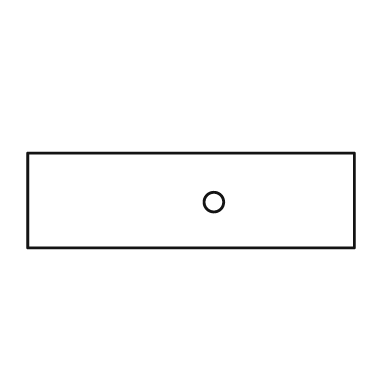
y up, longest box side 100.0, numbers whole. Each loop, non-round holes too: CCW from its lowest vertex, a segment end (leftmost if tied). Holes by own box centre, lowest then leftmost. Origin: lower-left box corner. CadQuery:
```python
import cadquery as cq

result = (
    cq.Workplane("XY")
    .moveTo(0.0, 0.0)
    .lineTo(100.0, 0.0)
    .lineTo(100.0, 29.0)
    .lineTo(0.0, 29.0)
    .close()
    .moveTo(57.0, 14.0)
    .circle(3.0)
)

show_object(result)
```